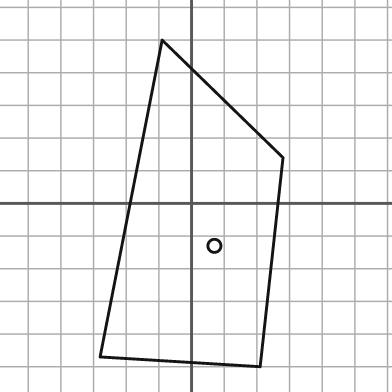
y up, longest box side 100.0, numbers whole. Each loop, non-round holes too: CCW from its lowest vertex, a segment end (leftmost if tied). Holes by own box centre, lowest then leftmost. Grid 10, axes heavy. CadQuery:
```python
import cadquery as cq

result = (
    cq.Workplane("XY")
    .moveTo(21.0, -50.0)
    .lineTo(28.0, 14.0)
    .lineTo(-9.0, 50.0)
    .lineTo(-28.0, -47.0)
    .close()
    .moveTo(7.0, -13.0)
    .circle(2.0)
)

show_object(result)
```